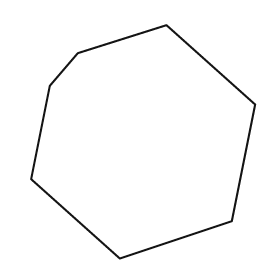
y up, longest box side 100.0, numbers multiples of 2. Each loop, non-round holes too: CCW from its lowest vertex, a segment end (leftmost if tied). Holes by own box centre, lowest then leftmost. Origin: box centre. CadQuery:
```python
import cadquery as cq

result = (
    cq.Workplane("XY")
    .moveTo(-10.0, -50.0)
    .lineTo(38.0, -34.0)
    .lineTo(48.0, 16.0)
    .lineTo(10.0, 50.0)
    .lineTo(-28.0, 38.0)
    .lineTo(-40.0, 24.0)
    .lineTo(-48.0, -16.0)
    .close()
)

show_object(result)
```